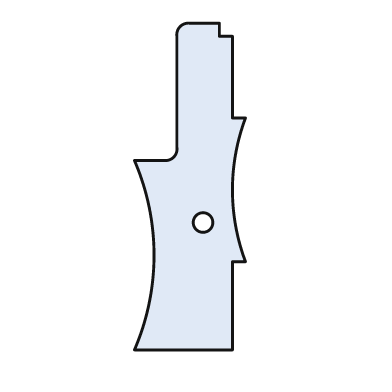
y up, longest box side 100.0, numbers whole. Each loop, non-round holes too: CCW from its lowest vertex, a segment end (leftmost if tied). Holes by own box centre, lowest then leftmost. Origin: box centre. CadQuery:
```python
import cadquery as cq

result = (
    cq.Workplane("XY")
    .moveTo(-17.0, -50.0)
    .lineTo(13.0, -50.0)
    .lineTo(13.0, -23.0)
    .lineTo(17.0, -23.0)
    .threePointArc((13.0, -1.0), (17.0, 21.0))
    .lineTo(13.0, 21.0)
    .lineTo(13.0, 46.0)
    .lineTo(9.0, 46.0)
    .lineTo(9.0, 50.0)
    .lineTo(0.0, 50.0)
    .threePointArc((-3.0, 49.0), (-4.0, 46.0))
    .lineTo(-4.0, 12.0)
    .threePointArc((-5.0, 9.0), (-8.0, 8.0))
    .lineTo(-17.0, 8.0)
    .threePointArc((-11.0, -21.0), (-17.0, -50.0))
    .close()
    .moveTo(4.0, -11.0)
    .circle(3.0)
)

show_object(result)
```